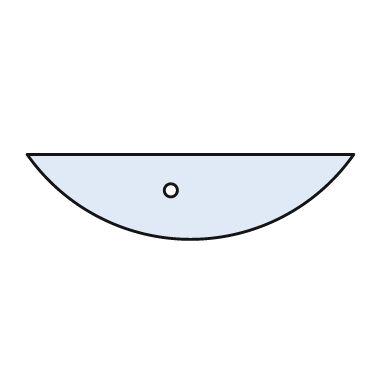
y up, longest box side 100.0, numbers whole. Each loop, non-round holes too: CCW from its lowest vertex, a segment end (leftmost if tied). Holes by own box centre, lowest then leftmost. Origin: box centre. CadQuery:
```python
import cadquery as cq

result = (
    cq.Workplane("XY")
    .moveTo(-50.0, 13.0)
    .threePointArc((0.0, -13.0), (50.0, 13.0))
    .close()
    .moveTo(-6.0, 2.0)
    .circle(2.0)
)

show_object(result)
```